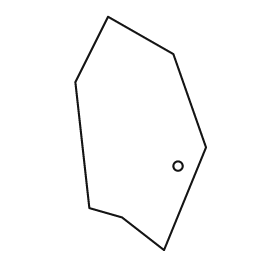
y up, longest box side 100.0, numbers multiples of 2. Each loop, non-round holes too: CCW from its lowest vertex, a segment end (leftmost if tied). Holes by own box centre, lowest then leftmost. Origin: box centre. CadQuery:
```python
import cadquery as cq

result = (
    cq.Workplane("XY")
    .moveTo(10.0, -50.0)
    .lineTo(28.0, -6.0)
    .lineTo(14.0, 34.0)
    .lineTo(-14.0, 50.0)
    .lineTo(-28.0, 22.0)
    .lineTo(-22.0, -32.0)
    .lineTo(-8.0, -36.0)
    .close()
    .moveTo(16.0, -14.0)
    .circle(2.0)
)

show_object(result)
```